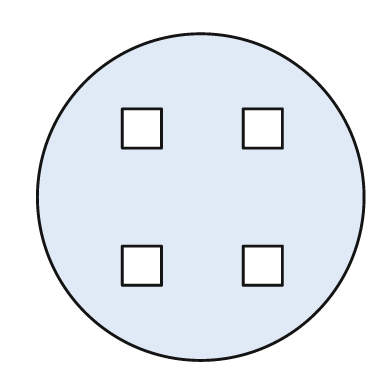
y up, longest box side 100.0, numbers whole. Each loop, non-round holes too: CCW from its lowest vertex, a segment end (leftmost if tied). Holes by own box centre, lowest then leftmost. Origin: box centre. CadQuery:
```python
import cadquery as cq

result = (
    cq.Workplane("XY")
    .moveTo(0.0, 0.0)
    .circle(50.0)
    .moveTo(-24.0, -27.0)
    .lineTo(-12.0, -27.0)
    .lineTo(-12.0, -15.0)
    .lineTo(-24.0, -15.0)
    .close()
    .moveTo(13.0, -27.0)
    .lineTo(25.0, -27.0)
    .lineTo(25.0, -15.0)
    .lineTo(13.0, -15.0)
    .close()
    .moveTo(-24.0, 15.0)
    .lineTo(-12.0, 15.0)
    .lineTo(-12.0, 27.0)
    .lineTo(-24.0, 27.0)
    .close()
    .moveTo(13.0, 15.0)
    .lineTo(25.0, 15.0)
    .lineTo(25.0, 27.0)
    .lineTo(13.0, 27.0)
    .close()
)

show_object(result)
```